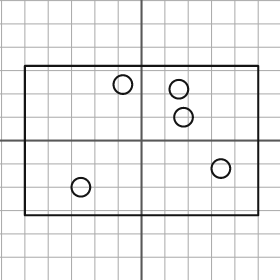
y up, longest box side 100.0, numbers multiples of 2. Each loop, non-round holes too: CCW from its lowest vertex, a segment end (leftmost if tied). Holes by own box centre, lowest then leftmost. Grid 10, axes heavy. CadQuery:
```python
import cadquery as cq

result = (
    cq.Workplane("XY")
    .moveTo(-50.0, -32.0)
    .lineTo(50.0, -32.0)
    .lineTo(50.0, 32.0)
    .lineTo(-50.0, 32.0)
    .close()
    .moveTo(-26.0, -20.0)
    .circle(4.0)
    .moveTo(34.0, -12.0)
    .circle(4.0)
    .moveTo(18.0, 10.0)
    .circle(4.0)
    .moveTo(16.0, 22.0)
    .circle(4.0)
    .moveTo(-8.0, 24.0)
    .circle(4.0)
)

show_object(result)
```